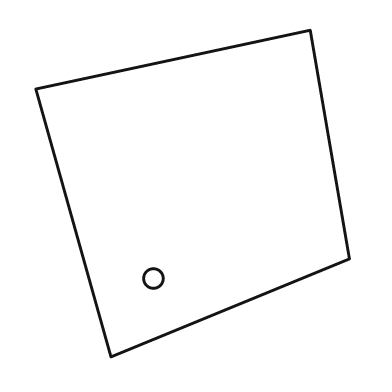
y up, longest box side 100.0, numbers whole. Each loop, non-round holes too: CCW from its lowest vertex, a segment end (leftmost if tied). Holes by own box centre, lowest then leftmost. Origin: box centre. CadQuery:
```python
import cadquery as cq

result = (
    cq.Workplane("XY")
    .moveTo(-25.0, -50.0)
    .lineTo(48.0, -20.0)
    .lineTo(36.0, 50.0)
    .lineTo(-48.0, 32.0)
    .close()
    .moveTo(-12.0, -26.0)
    .circle(3.0)
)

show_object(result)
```